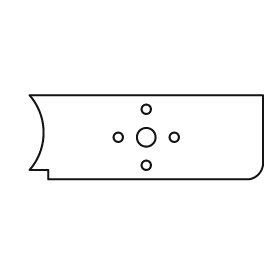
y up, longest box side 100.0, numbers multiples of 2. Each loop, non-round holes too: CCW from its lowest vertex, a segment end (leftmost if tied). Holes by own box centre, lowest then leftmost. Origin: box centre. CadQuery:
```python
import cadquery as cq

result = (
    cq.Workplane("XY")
    .moveTo(-42.0, -18.0)
    .lineTo(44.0, -18.0)
    .threePointArc((48.0, -16.0), (50.0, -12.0))
    .lineTo(50.0, 18.0)
    .lineTo(-50.0, 18.0)
    .threePointArc((-44.0, 2.0), (-50.0, -14.0))
    .lineTo(-42.0, -14.0)
    .close()
    .moveTo(0.0, -12.0)
    .circle(2.0)
    .moveTo(-12.0, 0.0)
    .circle(2.0)
    .moveTo(0.0, 0.0)
    .circle(4.0)
    .moveTo(12.0, 0.0)
    .circle(2.0)
    .moveTo(0.0, 12.0)
    .circle(2.0)
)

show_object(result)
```